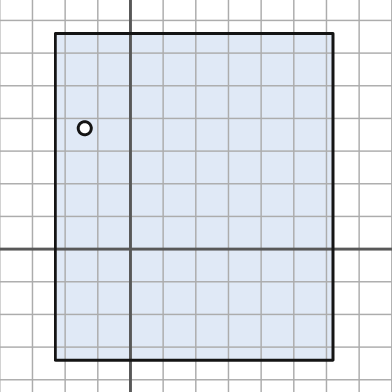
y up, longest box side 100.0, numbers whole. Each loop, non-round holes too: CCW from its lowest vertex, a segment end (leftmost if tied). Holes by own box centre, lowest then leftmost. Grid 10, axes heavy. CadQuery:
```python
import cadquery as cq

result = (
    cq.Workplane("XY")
    .moveTo(-23.0, -34.0)
    .lineTo(62.0, -34.0)
    .lineTo(62.0, 66.0)
    .lineTo(-23.0, 66.0)
    .close()
    .moveTo(-14.0, 37.0)
    .circle(2.0)
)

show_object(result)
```